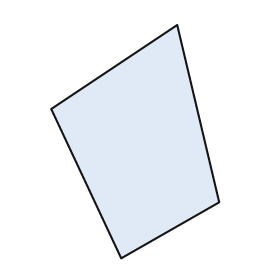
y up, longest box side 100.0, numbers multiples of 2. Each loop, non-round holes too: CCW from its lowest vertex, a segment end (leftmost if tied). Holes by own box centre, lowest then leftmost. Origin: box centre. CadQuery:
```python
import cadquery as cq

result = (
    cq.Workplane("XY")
    .moveTo(-6.0, -50.0)
    .lineTo(36.0, -26.0)
    .lineTo(18.0, 50.0)
    .lineTo(-36.0, 14.0)
    .close()
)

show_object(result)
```